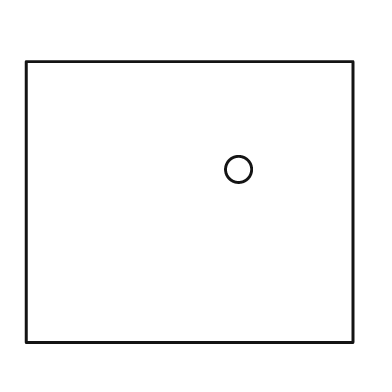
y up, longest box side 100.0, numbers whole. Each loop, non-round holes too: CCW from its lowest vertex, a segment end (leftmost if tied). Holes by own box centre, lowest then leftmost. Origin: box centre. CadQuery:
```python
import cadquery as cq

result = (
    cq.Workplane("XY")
    .moveTo(-50.0, -43.0)
    .lineTo(50.0, -43.0)
    .lineTo(50.0, 43.0)
    .lineTo(-50.0, 43.0)
    .close()
    .moveTo(15.0, 10.0)
    .circle(4.0)
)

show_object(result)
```